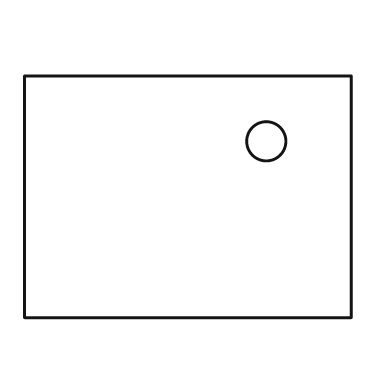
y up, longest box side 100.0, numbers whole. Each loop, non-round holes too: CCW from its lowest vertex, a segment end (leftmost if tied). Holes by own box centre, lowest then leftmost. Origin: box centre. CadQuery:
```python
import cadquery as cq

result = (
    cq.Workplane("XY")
    .moveTo(-50.0, -37.0)
    .lineTo(50.0, -37.0)
    .lineTo(50.0, 37.0)
    .lineTo(-50.0, 37.0)
    .close()
    .moveTo(24.0, 17.0)
    .circle(6.0)
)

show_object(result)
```